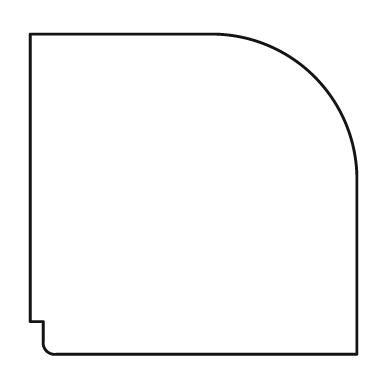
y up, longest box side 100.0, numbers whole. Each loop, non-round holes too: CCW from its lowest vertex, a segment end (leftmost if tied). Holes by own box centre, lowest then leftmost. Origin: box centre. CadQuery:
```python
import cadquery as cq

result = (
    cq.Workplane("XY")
    .moveTo(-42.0, -49.0)
    .lineTo(50.0, -49.0)
    .lineTo(50.0, 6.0)
    .threePointArc((37.0, 36.0), (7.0, 49.0))
    .lineTo(-50.0, 49.0)
    .lineTo(-50.0, -39.0)
    .lineTo(-46.0, -39.0)
    .lineTo(-46.0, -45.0)
    .threePointArc((-45.0, -48.0), (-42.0, -49.0))
    .close()
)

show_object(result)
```